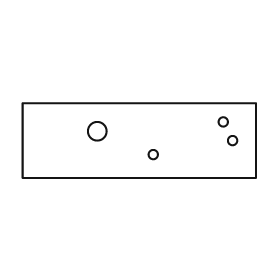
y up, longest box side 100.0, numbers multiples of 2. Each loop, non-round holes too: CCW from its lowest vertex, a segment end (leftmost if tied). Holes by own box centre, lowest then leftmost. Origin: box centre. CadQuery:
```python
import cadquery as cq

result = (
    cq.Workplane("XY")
    .moveTo(-50.0, -16.0)
    .lineTo(50.0, -16.0)
    .lineTo(50.0, 16.0)
    .lineTo(-50.0, 16.0)
    .close()
    .moveTo(6.0, -6.0)
    .circle(2.0)
    .moveTo(40.0, 0.0)
    .circle(2.0)
    .moveTo(-18.0, 4.0)
    .circle(4.0)
    .moveTo(36.0, 8.0)
    .circle(2.0)
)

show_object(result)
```